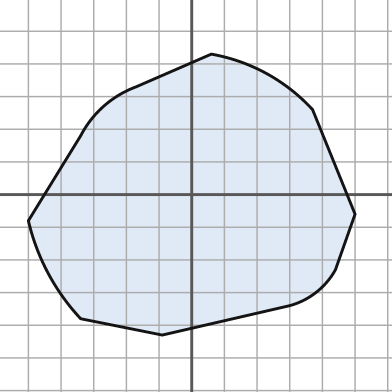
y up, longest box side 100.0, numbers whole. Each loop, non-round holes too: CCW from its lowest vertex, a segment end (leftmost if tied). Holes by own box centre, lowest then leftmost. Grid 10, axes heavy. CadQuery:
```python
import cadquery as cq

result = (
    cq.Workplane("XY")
    .moveTo(-9.0, -43.0)
    .lineTo(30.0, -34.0)
    .threePointArc((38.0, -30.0), (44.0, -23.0))
    .lineTo(50.0, -6.0)
    .lineTo(37.0, 26.0)
    .threePointArc((23.0, 37.0), (6.0, 43.0))
    .lineTo(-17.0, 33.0)
    .threePointArc((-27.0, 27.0), (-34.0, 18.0))
    .lineTo(-50.0, -8.0)
    .threePointArc((-44.0, -24.0), (-34.0, -38.0))
    .close()
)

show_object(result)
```